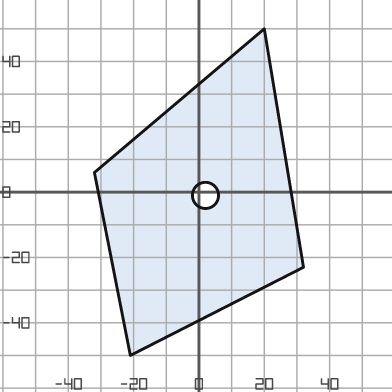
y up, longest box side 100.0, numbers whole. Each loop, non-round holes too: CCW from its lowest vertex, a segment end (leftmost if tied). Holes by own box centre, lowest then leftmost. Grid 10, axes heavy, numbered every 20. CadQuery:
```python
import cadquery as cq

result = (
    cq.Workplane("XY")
    .moveTo(-21.0, -50.0)
    .lineTo(32.0, -23.0)
    .lineTo(20.0, 50.0)
    .lineTo(-32.0, 6.0)
    .close()
    .moveTo(2.0, -1.0)
    .circle(4.0)
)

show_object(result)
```